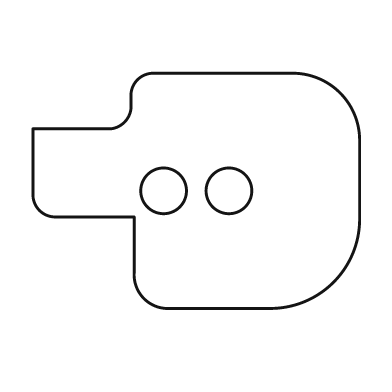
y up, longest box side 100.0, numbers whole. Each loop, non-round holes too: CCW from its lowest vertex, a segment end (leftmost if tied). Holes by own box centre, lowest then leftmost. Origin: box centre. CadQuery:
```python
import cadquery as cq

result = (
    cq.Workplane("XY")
    .moveTo(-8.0, -36.0)
    .lineTo(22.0, -36.0)
    .threePointArc((42.0, -28.0), (50.0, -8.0))
    .lineTo(50.0, 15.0)
    .threePointArc((44.0, 30.0), (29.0, 36.0))
    .lineTo(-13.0, 36.0)
    .threePointArc((-18.0, 34.0), (-20.0, 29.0))
    .lineTo(-20.0, 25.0)
    .threePointArc((-22.0, 21.0), (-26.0, 19.0))
    .lineTo(-50.0, 19.0)
    .lineTo(-50.0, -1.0)
    .threePointArc((-48.0, -6.0), (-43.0, -8.0))
    .lineTo(-19.0, -8.0)
    .lineTo(-19.0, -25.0)
    .threePointArc((-16.0, -33.0), (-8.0, -36.0))
    .close()
    .moveTo(-10.0, 0.0)
    .circle(7.0)
    .moveTo(10.0, 0.0)
    .circle(7.0)
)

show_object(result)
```